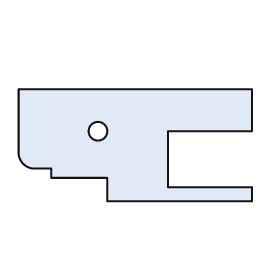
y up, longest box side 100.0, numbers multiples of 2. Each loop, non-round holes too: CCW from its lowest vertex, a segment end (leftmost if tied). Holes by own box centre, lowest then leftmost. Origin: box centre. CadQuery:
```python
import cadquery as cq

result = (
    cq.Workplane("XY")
    .moveTo(-12.0, -24.0)
    .lineTo(50.0, -24.0)
    .lineTo(50.0, -18.0)
    .lineTo(14.0, -18.0)
    .lineTo(14.0, 6.0)
    .lineTo(50.0, 6.0)
    .lineTo(50.0, 24.0)
    .lineTo(-50.0, 24.0)
    .lineTo(-50.0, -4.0)
    .threePointArc((-48.0, -8.0), (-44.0, -10.0))
    .lineTo(-36.0, -10.0)
    .lineTo(-36.0, -14.0)
    .lineTo(-12.0, -14.0)
    .close()
    .moveTo(-16.0, 6.0)
    .circle(4.0)
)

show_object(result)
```